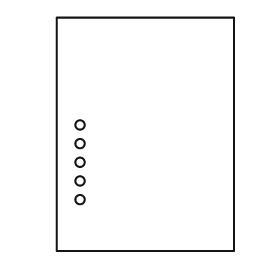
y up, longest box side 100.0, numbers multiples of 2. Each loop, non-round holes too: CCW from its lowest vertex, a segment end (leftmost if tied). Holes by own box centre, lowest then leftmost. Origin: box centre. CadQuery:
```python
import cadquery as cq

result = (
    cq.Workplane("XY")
    .moveTo(-38.0, -50.0)
    .lineTo(38.0, -50.0)
    .lineTo(38.0, 50.0)
    .lineTo(-38.0, 50.0)
    .close()
    .moveTo(-28.0, -28.0)
    .circle(2.0)
    .moveTo(-28.0, -20.0)
    .circle(2.0)
    .moveTo(-28.0, -12.0)
    .circle(2.0)
    .moveTo(-28.0, -4.0)
    .circle(2.0)
    .moveTo(-28.0, 4.0)
    .circle(2.0)
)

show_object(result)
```